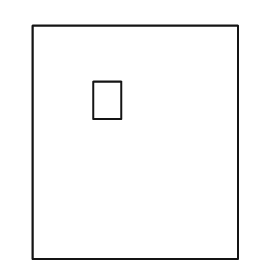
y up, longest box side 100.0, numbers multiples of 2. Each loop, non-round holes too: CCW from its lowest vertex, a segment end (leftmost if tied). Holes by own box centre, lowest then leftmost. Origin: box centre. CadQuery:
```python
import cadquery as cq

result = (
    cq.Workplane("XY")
    .moveTo(-44.0, -50.0)
    .lineTo(44.0, -50.0)
    .lineTo(44.0, 50.0)
    .lineTo(-44.0, 50.0)
    .close()
    .moveTo(-18.0, 10.0)
    .lineTo(-6.0, 10.0)
    .lineTo(-6.0, 26.0)
    .lineTo(-18.0, 26.0)
    .close()
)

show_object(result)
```